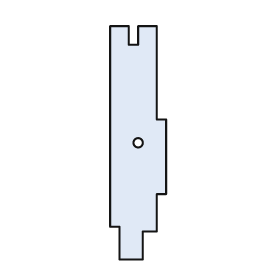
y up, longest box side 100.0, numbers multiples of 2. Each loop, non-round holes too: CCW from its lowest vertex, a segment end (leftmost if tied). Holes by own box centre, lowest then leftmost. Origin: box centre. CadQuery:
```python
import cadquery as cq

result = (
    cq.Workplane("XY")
    .moveTo(-8.0, -50.0)
    .lineTo(2.0, -50.0)
    .lineTo(2.0, -38.0)
    .lineTo(8.0, -38.0)
    .lineTo(8.0, -22.0)
    .lineTo(12.0, -22.0)
    .lineTo(12.0, 10.0)
    .lineTo(8.0, 10.0)
    .lineTo(8.0, 50.0)
    .lineTo(0.0, 50.0)
    .lineTo(0.0, 42.0)
    .lineTo(-4.0, 42.0)
    .lineTo(-4.0, 50.0)
    .lineTo(-12.0, 50.0)
    .lineTo(-12.0, -36.0)
    .lineTo(-8.0, -36.0)
    .close()
    .moveTo(0.0, 0.0)
    .circle(2.0)
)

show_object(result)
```